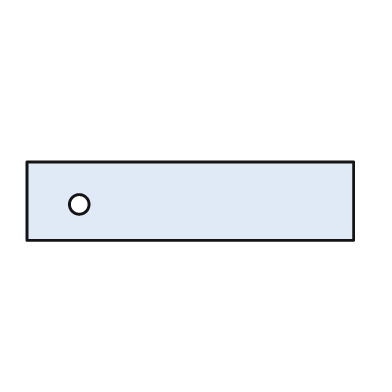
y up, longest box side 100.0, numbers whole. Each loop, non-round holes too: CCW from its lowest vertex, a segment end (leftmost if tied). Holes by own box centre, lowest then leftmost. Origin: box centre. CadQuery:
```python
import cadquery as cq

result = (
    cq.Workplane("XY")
    .moveTo(-50.0, -12.0)
    .lineTo(50.0, -12.0)
    .lineTo(50.0, 12.0)
    .lineTo(-50.0, 12.0)
    .close()
    .moveTo(-34.0, -1.0)
    .circle(3.0)
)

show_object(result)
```